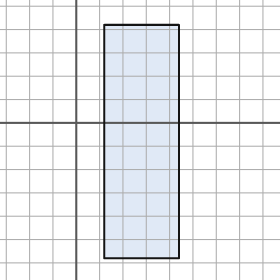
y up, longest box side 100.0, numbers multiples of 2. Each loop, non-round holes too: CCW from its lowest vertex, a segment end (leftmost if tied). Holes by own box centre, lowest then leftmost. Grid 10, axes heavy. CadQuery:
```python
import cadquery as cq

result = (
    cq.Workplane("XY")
    .moveTo(12.0, -58.0)
    .lineTo(44.0, -58.0)
    .lineTo(44.0, 42.0)
    .lineTo(12.0, 42.0)
    .close()
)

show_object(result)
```